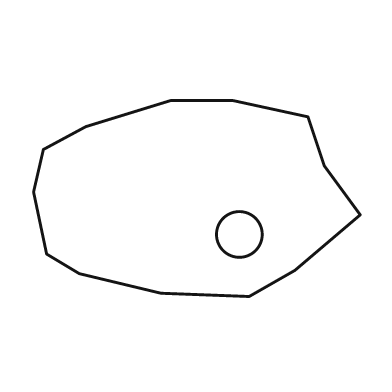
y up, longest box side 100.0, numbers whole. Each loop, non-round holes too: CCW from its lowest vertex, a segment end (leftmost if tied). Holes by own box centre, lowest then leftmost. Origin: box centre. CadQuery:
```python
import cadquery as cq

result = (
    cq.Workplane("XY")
    .moveTo(16.0, -30.0)
    .lineTo(30.0, -22.0)
    .lineTo(50.0, -5.0)
    .lineTo(39.0, 10.0)
    .lineTo(34.0, 25.0)
    .lineTo(11.0, 30.0)
    .lineTo(-8.0, 30.0)
    .lineTo(-34.0, 22.0)
    .lineTo(-47.0, 15.0)
    .lineTo(-50.0, 2.0)
    .lineTo(-46.0, -17.0)
    .lineTo(-36.0, -23.0)
    .lineTo(-11.0, -29.0)
    .close()
    .moveTo(13.0, -11.0)
    .circle(7.0)
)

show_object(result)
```